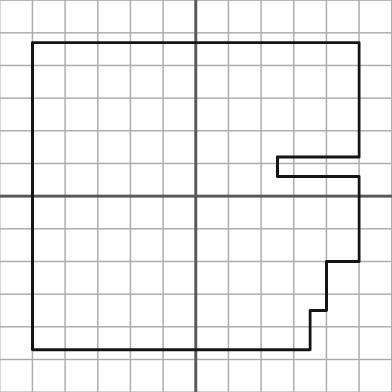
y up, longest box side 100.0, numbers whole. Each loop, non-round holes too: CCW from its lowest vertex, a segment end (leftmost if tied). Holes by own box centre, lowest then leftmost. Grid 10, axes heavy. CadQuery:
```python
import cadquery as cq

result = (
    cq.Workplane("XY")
    .moveTo(-50.0, -47.0)
    .lineTo(35.0, -47.0)
    .lineTo(35.0, -35.0)
    .lineTo(40.0, -35.0)
    .lineTo(40.0, -20.0)
    .lineTo(50.0, -20.0)
    .lineTo(50.0, 6.0)
    .lineTo(25.0, 6.0)
    .lineTo(25.0, 12.0)
    .lineTo(50.0, 12.0)
    .lineTo(50.0, 47.0)
    .lineTo(-50.0, 47.0)
    .close()
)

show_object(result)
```